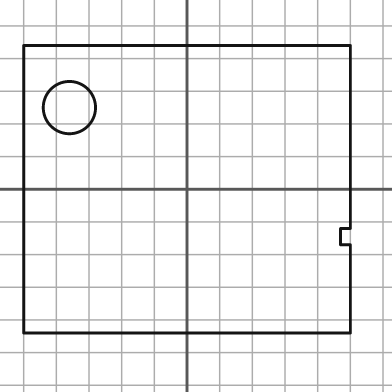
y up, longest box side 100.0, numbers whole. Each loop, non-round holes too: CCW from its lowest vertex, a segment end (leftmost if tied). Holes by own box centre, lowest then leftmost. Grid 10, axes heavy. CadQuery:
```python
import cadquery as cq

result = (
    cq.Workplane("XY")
    .moveTo(-50.0, -44.0)
    .lineTo(50.0, -44.0)
    .lineTo(50.0, -17.0)
    .lineTo(47.0, -17.0)
    .lineTo(47.0, -12.0)
    .lineTo(50.0, -12.0)
    .lineTo(50.0, 44.0)
    .lineTo(-50.0, 44.0)
    .close()
    .moveTo(-36.0, 25.0)
    .circle(8.0)
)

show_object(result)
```